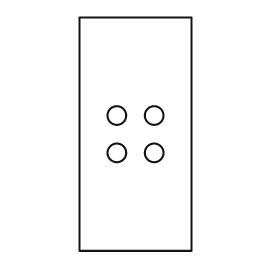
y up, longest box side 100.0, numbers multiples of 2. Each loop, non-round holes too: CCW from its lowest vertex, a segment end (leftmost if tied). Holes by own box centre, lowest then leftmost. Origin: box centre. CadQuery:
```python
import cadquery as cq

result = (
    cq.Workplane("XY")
    .moveTo(-24.0, -50.0)
    .lineTo(24.0, -50.0)
    .lineTo(24.0, 50.0)
    .lineTo(-24.0, 50.0)
    .close()
    .moveTo(-8.0, -8.0)
    .circle(4.0)
    .moveTo(8.0, -8.0)
    .circle(4.0)
    .moveTo(-8.0, 8.0)
    .circle(4.0)
    .moveTo(8.0, 8.0)
    .circle(4.0)
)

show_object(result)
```